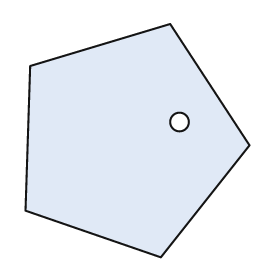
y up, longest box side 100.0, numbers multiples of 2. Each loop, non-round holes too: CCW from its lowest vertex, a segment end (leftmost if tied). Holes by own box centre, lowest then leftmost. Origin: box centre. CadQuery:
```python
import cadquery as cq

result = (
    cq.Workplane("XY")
    .moveTo(10.0, -50.0)
    .lineTo(48.0, -2.0)
    .lineTo(14.0, 50.0)
    .lineTo(-46.0, 32.0)
    .lineTo(-48.0, -30.0)
    .close()
    .moveTo(18.0, 8.0)
    .circle(4.0)
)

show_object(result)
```